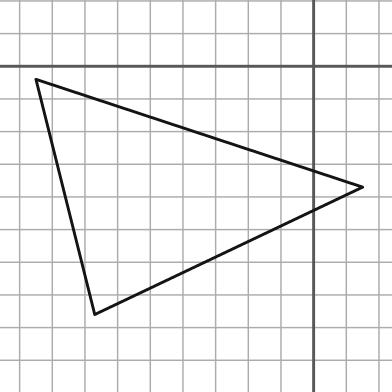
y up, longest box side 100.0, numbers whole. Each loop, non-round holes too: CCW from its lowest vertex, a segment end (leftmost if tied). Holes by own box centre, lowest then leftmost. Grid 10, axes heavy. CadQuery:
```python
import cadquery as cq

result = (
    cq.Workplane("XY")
    .moveTo(-67.0, -76.0)
    .lineTo(15.0, -37.0)
    .lineTo(-85.0, -4.0)
    .close()
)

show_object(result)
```